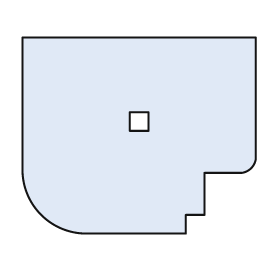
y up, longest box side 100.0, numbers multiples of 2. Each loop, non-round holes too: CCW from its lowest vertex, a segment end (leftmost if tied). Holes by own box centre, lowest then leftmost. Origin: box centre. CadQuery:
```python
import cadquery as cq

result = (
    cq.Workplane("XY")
    .moveTo(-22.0, -42.0)
    .lineTo(20.0, -42.0)
    .lineTo(20.0, -34.0)
    .lineTo(28.0, -34.0)
    .lineTo(28.0, -16.0)
    .lineTo(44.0, -16.0)
    .threePointArc((48.0, -14.0), (50.0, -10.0))
    .lineTo(50.0, 42.0)
    .lineTo(-50.0, 42.0)
    .lineTo(-50.0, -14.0)
    .threePointArc((-42.0, -34.0), (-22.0, -42.0))
    .close()
    .moveTo(-4.0, 2.0)
    .lineTo(4.0, 2.0)
    .lineTo(4.0, 10.0)
    .lineTo(-4.0, 10.0)
    .close()
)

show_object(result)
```